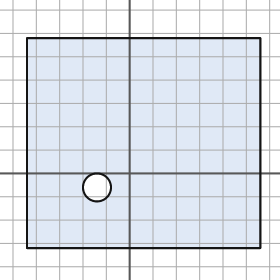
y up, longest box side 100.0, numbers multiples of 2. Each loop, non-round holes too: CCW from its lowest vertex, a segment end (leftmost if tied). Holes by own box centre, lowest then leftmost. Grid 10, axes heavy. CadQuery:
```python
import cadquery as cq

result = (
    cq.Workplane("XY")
    .moveTo(-44.0, -32.0)
    .lineTo(56.0, -32.0)
    .lineTo(56.0, 58.0)
    .lineTo(-44.0, 58.0)
    .close()
    .moveTo(-14.0, -6.0)
    .circle(6.0)
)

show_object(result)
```